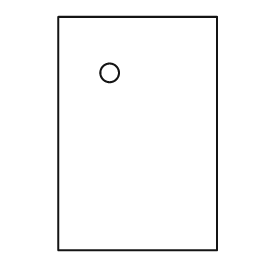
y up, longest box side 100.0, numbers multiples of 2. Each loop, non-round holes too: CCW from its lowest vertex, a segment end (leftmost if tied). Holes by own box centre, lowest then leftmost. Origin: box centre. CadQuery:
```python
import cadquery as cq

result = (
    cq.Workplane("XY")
    .moveTo(-34.0, -50.0)
    .lineTo(34.0, -50.0)
    .lineTo(34.0, 50.0)
    .lineTo(-34.0, 50.0)
    .close()
    .moveTo(-12.0, 26.0)
    .circle(4.0)
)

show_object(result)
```